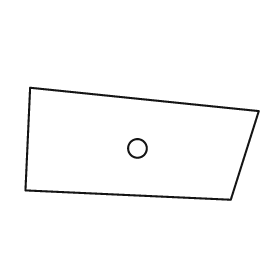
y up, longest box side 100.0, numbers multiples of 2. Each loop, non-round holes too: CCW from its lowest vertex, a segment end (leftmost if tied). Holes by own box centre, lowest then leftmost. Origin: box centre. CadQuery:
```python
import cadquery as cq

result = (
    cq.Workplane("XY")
    .moveTo(38.0, -24.0)
    .lineTo(50.0, 14.0)
    .lineTo(-48.0, 24.0)
    .lineTo(-50.0, -20.0)
    .close()
    .moveTo(-2.0, -2.0)
    .circle(4.0)
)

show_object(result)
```